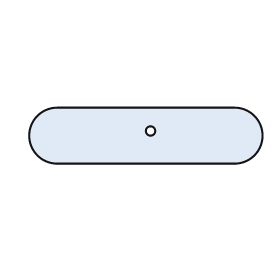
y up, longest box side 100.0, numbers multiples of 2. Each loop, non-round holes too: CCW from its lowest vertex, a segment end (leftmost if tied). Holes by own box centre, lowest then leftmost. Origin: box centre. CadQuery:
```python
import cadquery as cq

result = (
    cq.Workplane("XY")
    .moveTo(-38.0, -12.0)
    .lineTo(38.0, -12.0)
    .threePointArc((50.0, 0.0), (38.0, 12.0))
    .lineTo(-38.0, 12.0)
    .threePointArc((-50.0, 0.0), (-38.0, -12.0))
    .close()
    .moveTo(2.0, 2.0)
    .circle(2.0)
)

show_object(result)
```